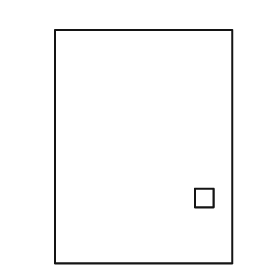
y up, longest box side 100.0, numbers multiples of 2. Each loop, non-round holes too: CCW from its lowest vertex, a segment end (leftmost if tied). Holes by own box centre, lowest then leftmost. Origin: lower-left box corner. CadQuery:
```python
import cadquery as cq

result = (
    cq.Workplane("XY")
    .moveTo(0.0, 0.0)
    .lineTo(76.0, 0.0)
    .lineTo(76.0, 100.0)
    .lineTo(0.0, 100.0)
    .close()
    .moveTo(60.0, 24.0)
    .lineTo(68.0, 24.0)
    .lineTo(68.0, 32.0)
    .lineTo(60.0, 32.0)
    .close()
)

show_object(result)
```